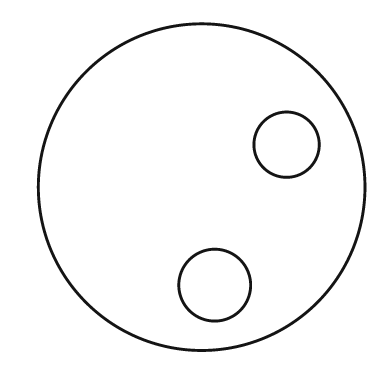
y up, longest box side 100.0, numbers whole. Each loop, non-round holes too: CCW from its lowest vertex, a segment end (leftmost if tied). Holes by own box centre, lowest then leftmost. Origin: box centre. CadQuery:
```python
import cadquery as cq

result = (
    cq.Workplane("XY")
    .moveTo(0.0, 0.0)
    .circle(50.0)
    .moveTo(4.0, -30.0)
    .circle(11.0)
    .moveTo(26.0, 13.0)
    .circle(10.0)
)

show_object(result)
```